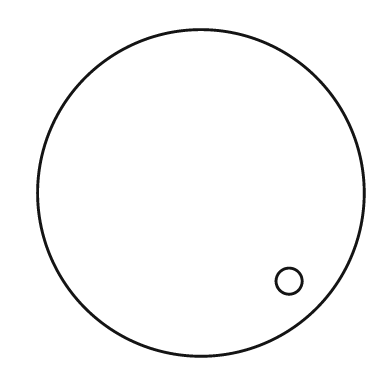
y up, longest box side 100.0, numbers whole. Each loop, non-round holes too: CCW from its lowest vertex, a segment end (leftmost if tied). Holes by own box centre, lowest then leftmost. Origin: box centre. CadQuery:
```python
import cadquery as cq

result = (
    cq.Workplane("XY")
    .moveTo(0.0, 0.0)
    .circle(50.0)
    .moveTo(27.0, -27.0)
    .circle(4.0)
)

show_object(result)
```